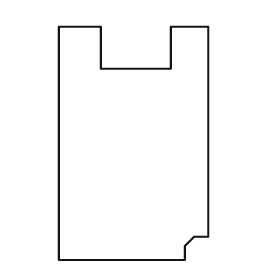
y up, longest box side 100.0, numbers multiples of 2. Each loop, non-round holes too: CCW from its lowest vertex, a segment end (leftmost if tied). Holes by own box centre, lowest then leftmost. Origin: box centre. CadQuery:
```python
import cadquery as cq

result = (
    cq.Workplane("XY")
    .moveTo(-32.0, -50.0)
    .lineTo(22.0, -50.0)
    .lineTo(22.0, -44.0)
    .lineTo(26.0, -40.0)
    .lineTo(32.0, -40.0)
    .lineTo(32.0, 50.0)
    .lineTo(16.0, 50.0)
    .lineTo(16.0, 32.0)
    .lineTo(-14.0, 32.0)
    .lineTo(-14.0, 50.0)
    .lineTo(-32.0, 50.0)
    .close()
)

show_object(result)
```